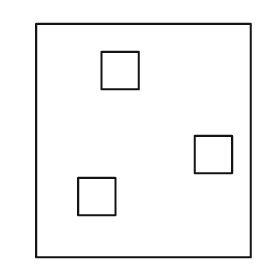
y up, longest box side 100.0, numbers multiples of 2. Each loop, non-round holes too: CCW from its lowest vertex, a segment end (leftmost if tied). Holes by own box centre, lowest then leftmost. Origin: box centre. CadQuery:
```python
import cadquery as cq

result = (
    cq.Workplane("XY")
    .moveTo(-46.0, -50.0)
    .lineTo(46.0, -50.0)
    .lineTo(46.0, 50.0)
    .lineTo(-46.0, 50.0)
    .close()
    .moveTo(-28.0, -32.0)
    .lineTo(-12.0, -32.0)
    .lineTo(-12.0, -16.0)
    .lineTo(-28.0, -16.0)
    .close()
    .moveTo(22.0, -14.0)
    .lineTo(38.0, -14.0)
    .lineTo(38.0, 2.0)
    .lineTo(22.0, 2.0)
    .close()
    .moveTo(-18.0, 22.0)
    .lineTo(-2.0, 22.0)
    .lineTo(-2.0, 38.0)
    .lineTo(-18.0, 38.0)
    .close()
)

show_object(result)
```